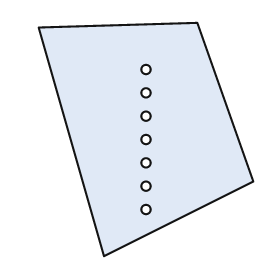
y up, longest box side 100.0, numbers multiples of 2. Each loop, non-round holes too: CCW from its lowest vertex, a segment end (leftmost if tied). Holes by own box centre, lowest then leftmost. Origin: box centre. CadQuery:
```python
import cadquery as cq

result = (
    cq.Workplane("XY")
    .moveTo(-18.0, -50.0)
    .lineTo(46.0, -18.0)
    .lineTo(22.0, 50.0)
    .lineTo(-46.0, 48.0)
    .close()
    .moveTo(0.0, -30.0)
    .circle(2.0)
    .moveTo(0.0, -20.0)
    .circle(2.0)
    .moveTo(0.0, -10.0)
    .circle(2.0)
    .moveTo(0.0, 0.0)
    .circle(2.0)
    .moveTo(0.0, 10.0)
    .circle(2.0)
    .moveTo(0.0, 20.0)
    .circle(2.0)
    .moveTo(0.0, 30.0)
    .circle(2.0)
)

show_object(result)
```